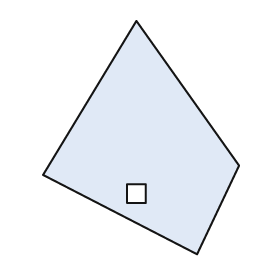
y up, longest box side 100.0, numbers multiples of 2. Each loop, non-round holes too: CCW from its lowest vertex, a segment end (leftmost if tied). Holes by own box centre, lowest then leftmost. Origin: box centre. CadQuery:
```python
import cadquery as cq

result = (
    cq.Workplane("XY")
    .moveTo(24.0, -50.0)
    .lineTo(42.0, -12.0)
    .lineTo(-2.0, 50.0)
    .lineTo(-42.0, -16.0)
    .close()
    .moveTo(-6.0, -28.0)
    .lineTo(2.0, -28.0)
    .lineTo(2.0, -20.0)
    .lineTo(-6.0, -20.0)
    .close()
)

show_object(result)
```